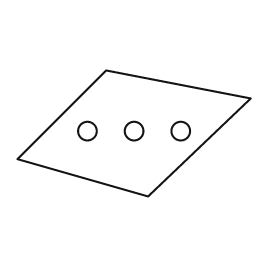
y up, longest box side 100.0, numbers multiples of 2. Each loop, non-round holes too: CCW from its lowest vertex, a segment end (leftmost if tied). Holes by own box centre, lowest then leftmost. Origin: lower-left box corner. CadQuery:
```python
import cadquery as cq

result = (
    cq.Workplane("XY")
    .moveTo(56.0, 0.0)
    .lineTo(100.0, 42.0)
    .lineTo(38.0, 54.0)
    .lineTo(0.0, 16.0)
    .close()
    .moveTo(30.0, 28.0)
    .circle(4.0)
    .moveTo(50.0, 28.0)
    .circle(4.0)
    .moveTo(70.0, 28.0)
    .circle(4.0)
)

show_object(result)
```